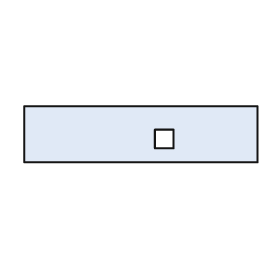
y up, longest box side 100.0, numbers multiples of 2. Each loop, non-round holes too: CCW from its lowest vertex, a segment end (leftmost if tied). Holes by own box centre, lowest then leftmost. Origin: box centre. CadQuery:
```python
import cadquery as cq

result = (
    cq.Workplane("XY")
    .moveTo(-50.0, -12.0)
    .lineTo(50.0, -12.0)
    .lineTo(50.0, 12.0)
    .lineTo(-50.0, 12.0)
    .close()
    .moveTo(6.0, -6.0)
    .lineTo(14.0, -6.0)
    .lineTo(14.0, 2.0)
    .lineTo(6.0, 2.0)
    .close()
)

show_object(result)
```